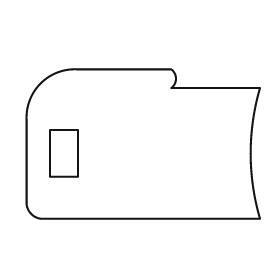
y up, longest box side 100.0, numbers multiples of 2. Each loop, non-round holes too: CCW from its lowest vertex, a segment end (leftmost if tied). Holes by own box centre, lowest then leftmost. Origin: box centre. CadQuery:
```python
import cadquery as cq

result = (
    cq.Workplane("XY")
    .moveTo(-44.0, -32.0)
    .lineTo(50.0, -32.0)
    .threePointArc((46.0, -4.0), (50.0, 24.0))
    .lineTo(12.0, 24.0)
    .threePointArc((14.0, 28.0), (12.0, 32.0))
    .lineTo(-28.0, 32.0)
    .threePointArc((-44.0, 26.0), (-50.0, 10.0))
    .lineTo(-50.0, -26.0)
    .threePointArc((-48.0, -30.0), (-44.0, -32.0))
    .close()
    .moveTo(-40.0, -14.0)
    .lineTo(-28.0, -14.0)
    .lineTo(-28.0, 6.0)
    .lineTo(-40.0, 6.0)
    .close()
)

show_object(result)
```